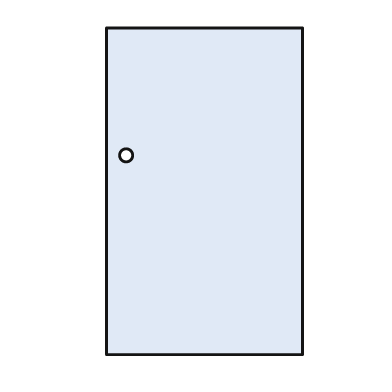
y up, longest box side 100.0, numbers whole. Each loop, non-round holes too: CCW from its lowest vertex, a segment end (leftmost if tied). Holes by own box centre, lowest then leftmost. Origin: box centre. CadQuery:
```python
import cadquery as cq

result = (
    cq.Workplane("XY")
    .moveTo(-30.0, -50.0)
    .lineTo(30.0, -50.0)
    .lineTo(30.0, 50.0)
    .lineTo(-30.0, 50.0)
    .close()
    .moveTo(-24.0, 11.0)
    .circle(2.0)
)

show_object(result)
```